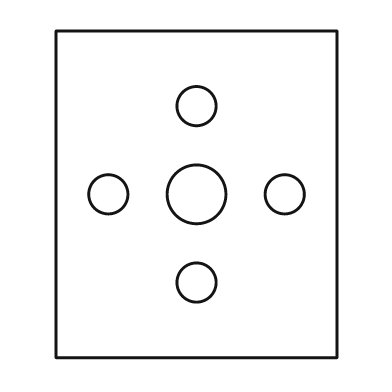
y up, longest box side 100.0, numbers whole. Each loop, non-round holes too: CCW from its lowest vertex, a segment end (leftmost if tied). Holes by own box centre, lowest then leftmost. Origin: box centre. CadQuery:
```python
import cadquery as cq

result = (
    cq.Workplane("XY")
    .moveTo(-43.0, -50.0)
    .lineTo(43.0, -50.0)
    .lineTo(43.0, 50.0)
    .lineTo(-43.0, 50.0)
    .close()
    .moveTo(0.0, -27.0)
    .circle(6.0)
    .moveTo(-27.0, 0.0)
    .circle(6.0)
    .moveTo(0.0, 0.0)
    .circle(9.0)
    .moveTo(27.0, 0.0)
    .circle(6.0)
    .moveTo(0.0, 27.0)
    .circle(6.0)
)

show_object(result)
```